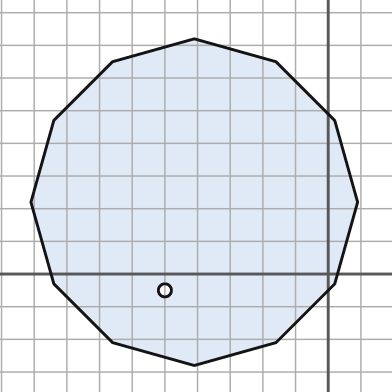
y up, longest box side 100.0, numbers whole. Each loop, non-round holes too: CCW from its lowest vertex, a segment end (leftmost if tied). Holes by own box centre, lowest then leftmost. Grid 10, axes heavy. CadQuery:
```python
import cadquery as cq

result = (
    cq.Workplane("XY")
    .moveTo(-41.0, -28.0)
    .lineTo(-16.0, -21.0)
    .lineTo(2.0, -3.0)
    .lineTo(9.0, 22.0)
    .lineTo(2.0, 47.0)
    .lineTo(-16.0, 65.0)
    .lineTo(-41.0, 72.0)
    .lineTo(-66.0, 65.0)
    .lineTo(-84.0, 47.0)
    .lineTo(-91.0, 22.0)
    .lineTo(-84.0, -3.0)
    .lineTo(-66.0, -21.0)
    .close()
    .moveTo(-50.0, -5.0)
    .circle(2.0)
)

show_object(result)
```